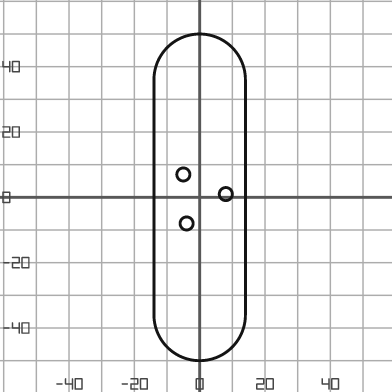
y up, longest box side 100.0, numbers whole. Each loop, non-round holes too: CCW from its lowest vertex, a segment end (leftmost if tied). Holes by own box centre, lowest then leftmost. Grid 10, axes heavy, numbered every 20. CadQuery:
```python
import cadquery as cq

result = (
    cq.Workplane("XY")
    .moveTo(-14.0, -36.0)
    .threePointArc((0.0, -50.0), (14.0, -36.0))
    .lineTo(14.0, 36.0)
    .threePointArc((0.0, 50.0), (-14.0, 36.0))
    .close()
    .moveTo(-4.0, -8.0)
    .circle(2.0)
    .moveTo(8.0, 1.0)
    .circle(2.0)
    .moveTo(-5.0, 7.0)
    .circle(2.0)
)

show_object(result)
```